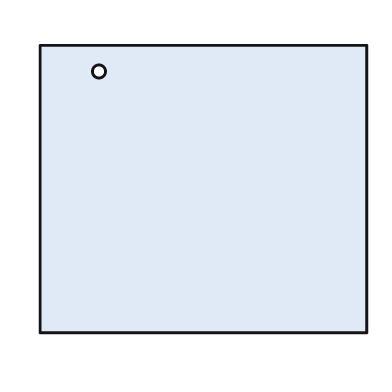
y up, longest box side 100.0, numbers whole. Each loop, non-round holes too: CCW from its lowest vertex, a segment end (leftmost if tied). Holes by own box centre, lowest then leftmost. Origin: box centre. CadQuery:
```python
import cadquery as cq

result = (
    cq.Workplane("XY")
    .moveTo(-50.0, -44.0)
    .lineTo(50.0, -44.0)
    .lineTo(50.0, 44.0)
    .lineTo(-50.0, 44.0)
    .close()
    .moveTo(-32.0, 36.0)
    .circle(2.0)
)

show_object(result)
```